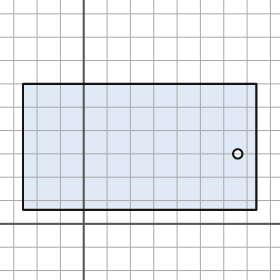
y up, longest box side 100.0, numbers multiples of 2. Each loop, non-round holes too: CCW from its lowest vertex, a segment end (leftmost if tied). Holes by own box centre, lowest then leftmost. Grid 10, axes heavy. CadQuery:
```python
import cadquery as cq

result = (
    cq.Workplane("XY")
    .moveTo(-26.0, 6.0)
    .lineTo(74.0, 6.0)
    .lineTo(74.0, 60.0)
    .lineTo(-26.0, 60.0)
    .close()
    .moveTo(66.0, 30.0)
    .circle(2.0)
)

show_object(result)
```